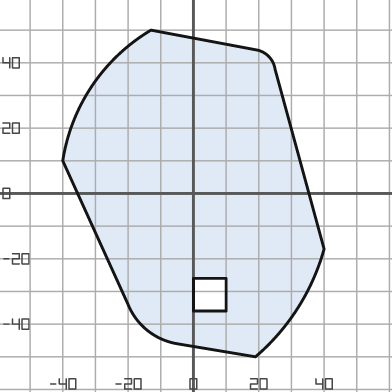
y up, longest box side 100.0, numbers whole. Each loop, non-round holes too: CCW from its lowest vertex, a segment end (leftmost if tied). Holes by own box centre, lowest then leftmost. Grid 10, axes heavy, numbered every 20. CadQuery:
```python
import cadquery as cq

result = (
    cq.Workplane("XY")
    .moveTo(19.0, -50.0)
    .threePointArc((32.0, -35.0), (40.0, -17.0))
    .lineTo(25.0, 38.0)
    .threePointArc((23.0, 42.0), (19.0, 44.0))
    .lineTo(-13.0, 50.0)
    .threePointArc((-31.0, 33.0), (-40.0, 10.0))
    .lineTo(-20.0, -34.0)
    .threePointArc((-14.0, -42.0), (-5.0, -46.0))
    .close()
    .moveTo(0.0, -36.0)
    .lineTo(10.0, -36.0)
    .lineTo(10.0, -26.0)
    .lineTo(0.0, -26.0)
    .close()
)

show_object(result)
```